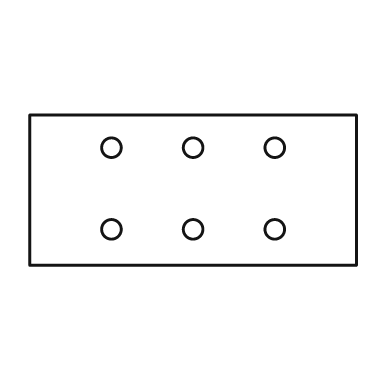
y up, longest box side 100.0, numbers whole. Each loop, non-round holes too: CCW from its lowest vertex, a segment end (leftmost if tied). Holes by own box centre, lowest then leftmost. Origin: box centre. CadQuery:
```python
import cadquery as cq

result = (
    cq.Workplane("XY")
    .moveTo(-50.0, -23.0)
    .lineTo(50.0, -23.0)
    .lineTo(50.0, 23.0)
    .lineTo(-50.0, 23.0)
    .close()
    .moveTo(-25.0, -12.0)
    .circle(3.0)
    .moveTo(0.0, -12.0)
    .circle(3.0)
    .moveTo(25.0, -12.0)
    .circle(3.0)
    .moveTo(-25.0, 13.0)
    .circle(3.0)
    .moveTo(0.0, 13.0)
    .circle(3.0)
    .moveTo(25.0, 13.0)
    .circle(3.0)
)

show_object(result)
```